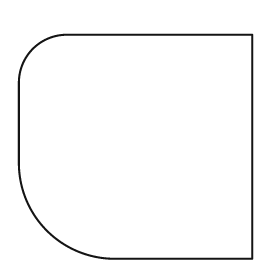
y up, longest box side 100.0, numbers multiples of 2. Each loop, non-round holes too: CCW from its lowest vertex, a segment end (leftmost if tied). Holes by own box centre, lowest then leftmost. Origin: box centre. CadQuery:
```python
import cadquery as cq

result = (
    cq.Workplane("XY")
    .moveTo(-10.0, -48.0)
    .lineTo(50.0, -48.0)
    .lineTo(50.0, 48.0)
    .lineTo(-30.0, 48.0)
    .threePointArc((-44.0, 42.0), (-50.0, 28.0))
    .lineTo(-50.0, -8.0)
    .threePointArc((-38.0, -36.0), (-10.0, -48.0))
    .close()
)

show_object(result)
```